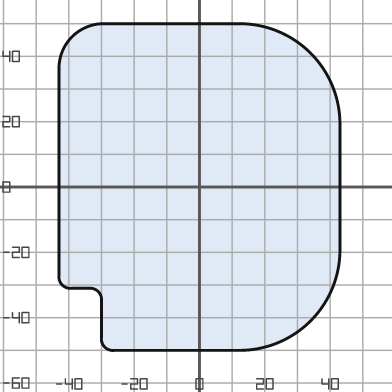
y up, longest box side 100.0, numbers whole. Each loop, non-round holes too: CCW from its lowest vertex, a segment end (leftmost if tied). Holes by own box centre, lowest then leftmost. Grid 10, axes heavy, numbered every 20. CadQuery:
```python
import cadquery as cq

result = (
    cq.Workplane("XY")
    .moveTo(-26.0, -50.0)
    .lineTo(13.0, -50.0)
    .threePointArc((34.0, -41.0), (43.0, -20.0))
    .lineTo(43.0, 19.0)
    .threePointArc((34.0, 41.0), (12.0, 50.0))
    .lineTo(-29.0, 50.0)
    .threePointArc((-39.0, 46.0), (-43.0, 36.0))
    .lineTo(-43.0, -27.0)
    .threePointArc((-42.0, -30.0), (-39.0, -31.0))
    .lineTo(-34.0, -31.0)
    .threePointArc((-31.0, -32.0), (-30.0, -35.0))
    .lineTo(-30.0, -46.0)
    .threePointArc((-29.0, -49.0), (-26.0, -50.0))
    .close()
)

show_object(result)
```